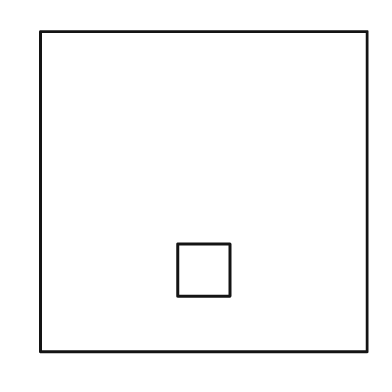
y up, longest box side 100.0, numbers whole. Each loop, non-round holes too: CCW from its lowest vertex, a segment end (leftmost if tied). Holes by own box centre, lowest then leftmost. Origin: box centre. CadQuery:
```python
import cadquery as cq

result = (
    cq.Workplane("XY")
    .moveTo(-50.0, -49.0)
    .lineTo(50.0, -49.0)
    .lineTo(50.0, 49.0)
    .lineTo(-50.0, 49.0)
    .close()
    .moveTo(-8.0, -32.0)
    .lineTo(8.0, -32.0)
    .lineTo(8.0, -16.0)
    .lineTo(-8.0, -16.0)
    .close()
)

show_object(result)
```